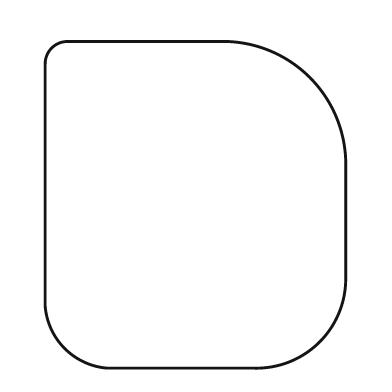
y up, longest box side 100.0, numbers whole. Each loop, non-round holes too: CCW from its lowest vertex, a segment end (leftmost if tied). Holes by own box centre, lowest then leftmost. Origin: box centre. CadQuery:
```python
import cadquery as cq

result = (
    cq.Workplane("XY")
    .moveTo(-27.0, -50.0)
    .lineTo(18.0, -50.0)
    .threePointArc((38.0, -42.0), (46.0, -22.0))
    .lineTo(46.0, 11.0)
    .threePointArc((35.0, 39.0), (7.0, 50.0))
    .lineTo(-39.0, 50.0)
    .threePointArc((-44.0, 48.0), (-46.0, 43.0))
    .lineTo(-46.0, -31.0)
    .threePointArc((-40.0, -44.0), (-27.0, -50.0))
    .close()
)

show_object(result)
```